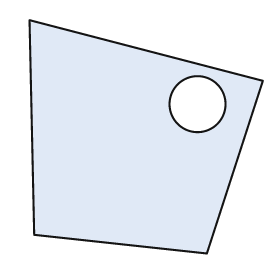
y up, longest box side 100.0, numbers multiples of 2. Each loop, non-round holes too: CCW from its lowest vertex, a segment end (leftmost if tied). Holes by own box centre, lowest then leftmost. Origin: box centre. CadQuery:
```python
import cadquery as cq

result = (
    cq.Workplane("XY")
    .moveTo(26.0, -50.0)
    .lineTo(50.0, 24.0)
    .lineTo(-50.0, 50.0)
    .lineTo(-48.0, -42.0)
    .close()
    .moveTo(22.0, 14.0)
    .circle(12.0)
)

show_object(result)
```